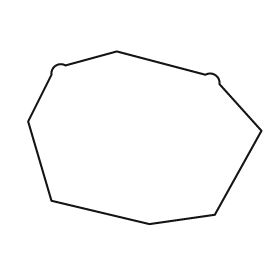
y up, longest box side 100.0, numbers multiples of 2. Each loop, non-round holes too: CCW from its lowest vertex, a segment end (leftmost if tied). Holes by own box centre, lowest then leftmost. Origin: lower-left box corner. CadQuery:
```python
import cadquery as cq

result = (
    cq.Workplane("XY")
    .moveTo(52.0, 0.0)
    .lineTo(80.0, 4.0)
    .lineTo(100.0, 40.0)
    .lineTo(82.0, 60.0)
    .threePointArc((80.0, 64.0), (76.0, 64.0))
    .lineTo(38.0, 74.0)
    .lineTo(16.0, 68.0)
    .threePointArc((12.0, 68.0), (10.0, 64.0))
    .lineTo(0.0, 44.0)
    .lineTo(10.0, 10.0)
    .close()
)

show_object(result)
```